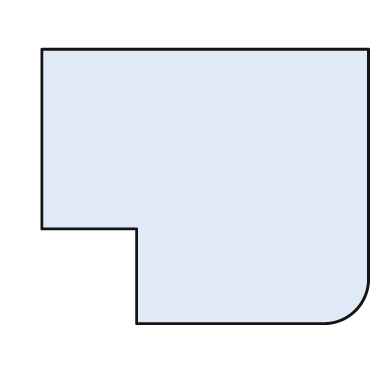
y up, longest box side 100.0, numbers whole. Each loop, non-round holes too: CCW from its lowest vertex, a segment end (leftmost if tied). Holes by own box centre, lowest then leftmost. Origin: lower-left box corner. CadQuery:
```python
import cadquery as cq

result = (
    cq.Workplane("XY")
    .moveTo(29.0, 0.0)
    .lineTo(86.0, 0.0)
    .threePointArc((96.0, 4.0), (100.0, 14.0))
    .lineTo(100.0, 84.0)
    .lineTo(0.0, 84.0)
    .lineTo(0.0, 29.0)
    .lineTo(29.0, 29.0)
    .close()
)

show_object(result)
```